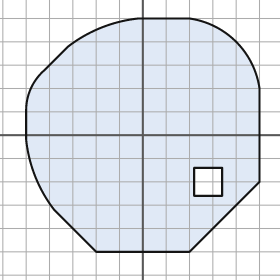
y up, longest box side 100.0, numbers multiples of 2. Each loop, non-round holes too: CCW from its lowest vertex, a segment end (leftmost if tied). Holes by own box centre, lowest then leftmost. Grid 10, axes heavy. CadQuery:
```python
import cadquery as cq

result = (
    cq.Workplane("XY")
    .moveTo(-20.0, -50.0)
    .lineTo(20.0, -50.0)
    .lineTo(50.0, -20.0)
    .lineTo(50.0, 20.0)
    .threePointArc((40.0, 40.0), (20.0, 50.0))
    .lineTo(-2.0, 50.0)
    .threePointArc((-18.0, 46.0), (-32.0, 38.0))
    .lineTo(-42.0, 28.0)
    .threePointArc((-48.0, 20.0), (-50.0, 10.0))
    .lineTo(-50.0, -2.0)
    .threePointArc((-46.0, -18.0), (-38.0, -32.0))
    .close()
    .moveTo(22.0, -26.0)
    .lineTo(34.0, -26.0)
    .lineTo(34.0, -14.0)
    .lineTo(22.0, -14.0)
    .close()
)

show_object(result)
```